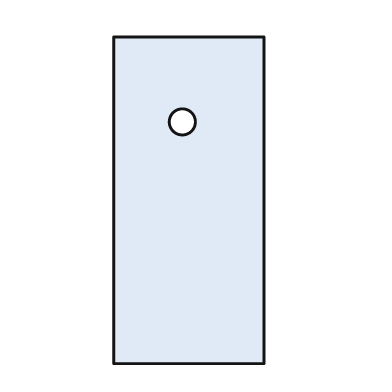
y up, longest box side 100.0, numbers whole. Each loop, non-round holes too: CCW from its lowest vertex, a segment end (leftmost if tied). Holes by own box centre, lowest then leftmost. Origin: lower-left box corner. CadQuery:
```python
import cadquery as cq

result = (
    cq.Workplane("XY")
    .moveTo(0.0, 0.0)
    .lineTo(46.0, 0.0)
    .lineTo(46.0, 100.0)
    .lineTo(0.0, 100.0)
    .close()
    .moveTo(21.0, 74.0)
    .circle(4.0)
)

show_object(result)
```